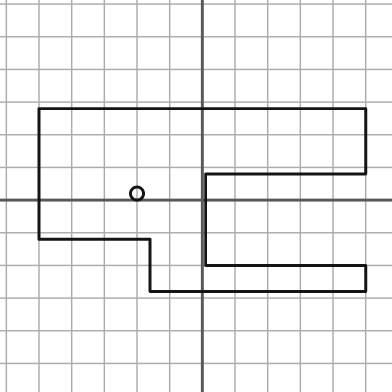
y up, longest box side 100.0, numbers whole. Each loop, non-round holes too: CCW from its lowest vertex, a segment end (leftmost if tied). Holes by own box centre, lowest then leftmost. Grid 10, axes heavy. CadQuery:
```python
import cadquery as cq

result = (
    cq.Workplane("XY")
    .moveTo(-16.0, -28.0)
    .lineTo(50.0, -28.0)
    .lineTo(50.0, -20.0)
    .lineTo(1.0, -20.0)
    .lineTo(1.0, 8.0)
    .lineTo(50.0, 8.0)
    .lineTo(50.0, 28.0)
    .lineTo(-50.0, 28.0)
    .lineTo(-50.0, -12.0)
    .lineTo(-16.0, -12.0)
    .close()
    .moveTo(-20.0, 2.0)
    .circle(2.0)
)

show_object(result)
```